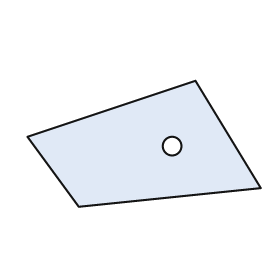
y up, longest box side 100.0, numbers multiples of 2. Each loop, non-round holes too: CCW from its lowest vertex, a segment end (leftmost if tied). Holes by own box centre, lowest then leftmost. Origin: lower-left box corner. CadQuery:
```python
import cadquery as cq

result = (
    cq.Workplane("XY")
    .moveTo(22.0, 0.0)
    .lineTo(100.0, 8.0)
    .lineTo(72.0, 54.0)
    .lineTo(0.0, 30.0)
    .close()
    .moveTo(62.0, 26.0)
    .circle(4.0)
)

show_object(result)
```